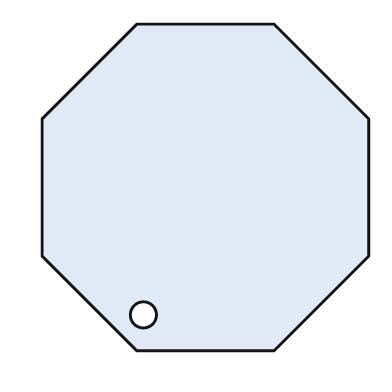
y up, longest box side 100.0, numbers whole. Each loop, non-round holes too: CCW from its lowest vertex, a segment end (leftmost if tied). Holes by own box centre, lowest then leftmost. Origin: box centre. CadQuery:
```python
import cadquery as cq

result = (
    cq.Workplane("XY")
    .moveTo(-21.0, -50.0)
    .lineTo(21.0, -50.0)
    .lineTo(50.0, -21.0)
    .lineTo(50.0, 21.0)
    .lineTo(21.0, 50.0)
    .lineTo(-21.0, 50.0)
    .lineTo(-50.0, 21.0)
    .lineTo(-50.0, -21.0)
    .close()
    .moveTo(-19.0, -39.0)
    .circle(4.0)
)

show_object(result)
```